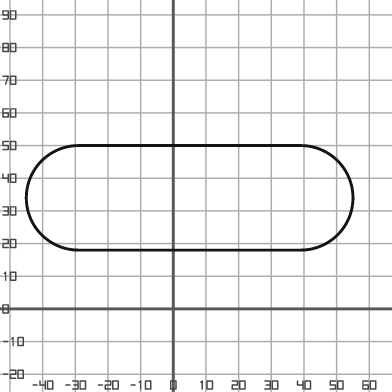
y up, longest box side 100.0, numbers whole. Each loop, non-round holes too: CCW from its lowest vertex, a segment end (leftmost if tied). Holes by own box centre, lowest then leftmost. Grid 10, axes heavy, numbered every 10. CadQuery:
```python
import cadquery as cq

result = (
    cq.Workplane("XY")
    .moveTo(-29.0, 18.0)
    .lineTo(39.0, 18.0)
    .threePointArc((55.0, 34.0), (39.0, 50.0))
    .lineTo(-29.0, 50.0)
    .threePointArc((-45.0, 34.0), (-29.0, 18.0))
    .close()
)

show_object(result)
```